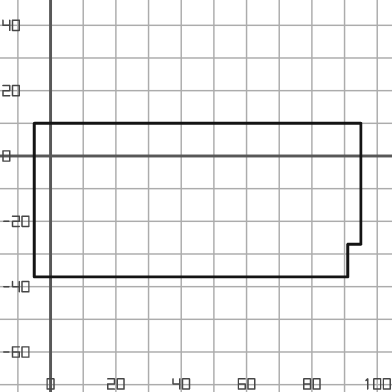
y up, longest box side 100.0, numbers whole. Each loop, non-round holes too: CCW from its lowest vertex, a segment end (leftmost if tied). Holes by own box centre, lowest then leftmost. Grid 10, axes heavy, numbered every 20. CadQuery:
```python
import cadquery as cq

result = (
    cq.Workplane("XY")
    .moveTo(-5.0, -37.0)
    .lineTo(91.0, -37.0)
    .lineTo(91.0, -27.0)
    .lineTo(95.0, -27.0)
    .lineTo(95.0, 10.0)
    .lineTo(-5.0, 10.0)
    .close()
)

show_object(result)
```